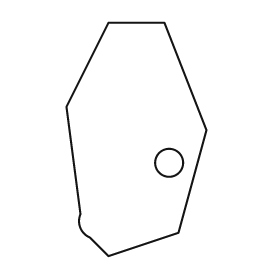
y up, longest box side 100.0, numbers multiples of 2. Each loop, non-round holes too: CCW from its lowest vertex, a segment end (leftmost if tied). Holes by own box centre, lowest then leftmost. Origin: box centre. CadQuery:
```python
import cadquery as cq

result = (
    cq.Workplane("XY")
    .moveTo(-12.0, -50.0)
    .lineTo(18.0, -40.0)
    .lineTo(30.0, 4.0)
    .lineTo(12.0, 50.0)
    .lineTo(-12.0, 50.0)
    .lineTo(-30.0, 14.0)
    .lineTo(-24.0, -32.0)
    .threePointArc((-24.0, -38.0), (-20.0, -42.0))
    .close()
    .moveTo(14.0, -10.0)
    .circle(6.0)
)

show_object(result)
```